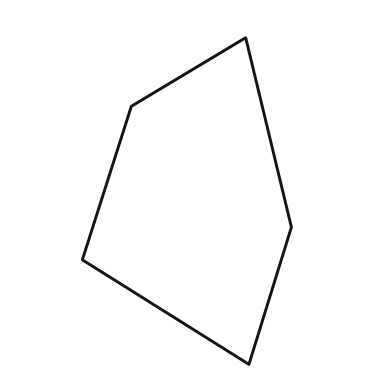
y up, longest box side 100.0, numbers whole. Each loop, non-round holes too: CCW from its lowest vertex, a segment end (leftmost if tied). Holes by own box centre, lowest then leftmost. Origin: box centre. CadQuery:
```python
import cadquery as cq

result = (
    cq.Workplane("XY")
    .moveTo(19.0, -50.0)
    .lineTo(32.0, -8.0)
    .lineTo(18.0, 50.0)
    .lineTo(-17.0, 29.0)
    .lineTo(-32.0, -18.0)
    .close()
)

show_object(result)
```